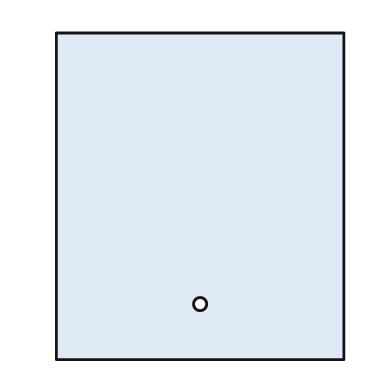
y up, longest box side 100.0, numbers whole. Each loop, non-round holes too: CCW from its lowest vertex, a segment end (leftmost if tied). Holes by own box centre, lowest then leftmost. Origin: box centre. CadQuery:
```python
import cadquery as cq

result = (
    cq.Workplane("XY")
    .moveTo(-44.0, -50.0)
    .lineTo(44.0, -50.0)
    .lineTo(44.0, 50.0)
    .lineTo(-44.0, 50.0)
    .close()
    .moveTo(0.0, -33.0)
    .circle(2.0)
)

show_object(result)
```